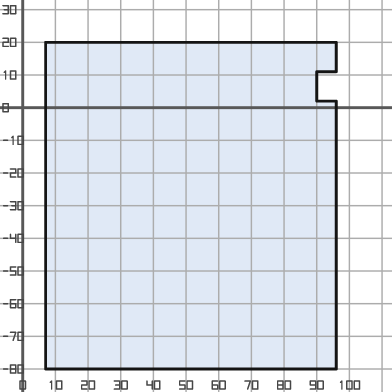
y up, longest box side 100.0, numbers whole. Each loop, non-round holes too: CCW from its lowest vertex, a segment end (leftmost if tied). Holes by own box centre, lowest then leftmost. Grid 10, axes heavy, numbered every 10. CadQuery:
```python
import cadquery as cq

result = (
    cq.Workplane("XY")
    .moveTo(7.0, -80.0)
    .lineTo(96.0, -80.0)
    .lineTo(96.0, 2.0)
    .lineTo(90.0, 2.0)
    .lineTo(90.0, 11.0)
    .lineTo(96.0, 11.0)
    .lineTo(96.0, 20.0)
    .lineTo(7.0, 20.0)
    .close()
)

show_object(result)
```